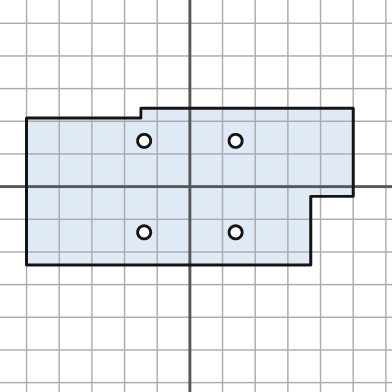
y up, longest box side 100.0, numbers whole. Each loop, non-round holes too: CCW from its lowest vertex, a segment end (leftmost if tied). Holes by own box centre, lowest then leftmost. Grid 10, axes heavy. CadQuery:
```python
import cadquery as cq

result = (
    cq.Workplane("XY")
    .moveTo(-50.0, -24.0)
    .lineTo(37.0, -24.0)
    .lineTo(37.0, -3.0)
    .lineTo(50.0, -3.0)
    .lineTo(50.0, 24.0)
    .lineTo(-15.0, 24.0)
    .lineTo(-15.0, 21.0)
    .lineTo(-50.0, 21.0)
    .close()
    .moveTo(-14.0, -14.0)
    .circle(2.0)
    .moveTo(14.0, -14.0)
    .circle(2.0)
    .moveTo(-14.0, 14.0)
    .circle(2.0)
    .moveTo(14.0, 14.0)
    .circle(2.0)
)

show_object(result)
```